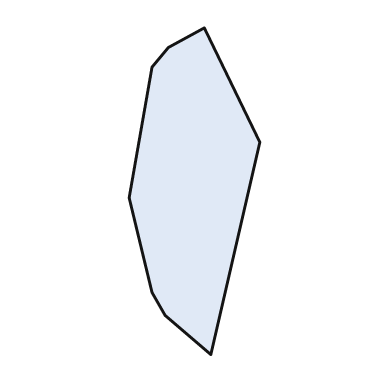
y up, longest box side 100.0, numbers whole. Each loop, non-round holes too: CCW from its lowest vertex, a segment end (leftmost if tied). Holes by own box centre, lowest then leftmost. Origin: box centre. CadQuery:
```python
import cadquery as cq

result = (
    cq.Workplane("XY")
    .moveTo(5.0, -50.0)
    .lineTo(20.0, 15.0)
    .lineTo(3.0, 50.0)
    .lineTo(-8.0, 44.0)
    .lineTo(-13.0, 38.0)
    .lineTo(-20.0, -2.0)
    .lineTo(-13.0, -31.0)
    .lineTo(-9.0, -38.0)
    .close()
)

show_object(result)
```